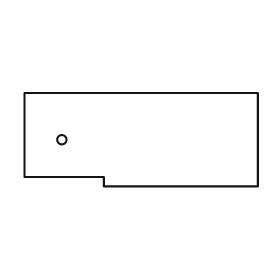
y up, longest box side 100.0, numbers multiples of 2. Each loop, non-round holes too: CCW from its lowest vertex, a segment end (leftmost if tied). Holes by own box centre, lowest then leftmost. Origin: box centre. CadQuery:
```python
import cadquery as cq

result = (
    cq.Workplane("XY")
    .moveTo(-16.0, -20.0)
    .lineTo(50.0, -20.0)
    .lineTo(50.0, 20.0)
    .lineTo(-50.0, 20.0)
    .lineTo(-50.0, -16.0)
    .lineTo(-16.0, -16.0)
    .close()
    .moveTo(-34.0, 0.0)
    .circle(2.0)
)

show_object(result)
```